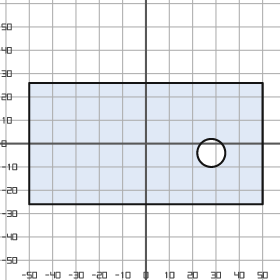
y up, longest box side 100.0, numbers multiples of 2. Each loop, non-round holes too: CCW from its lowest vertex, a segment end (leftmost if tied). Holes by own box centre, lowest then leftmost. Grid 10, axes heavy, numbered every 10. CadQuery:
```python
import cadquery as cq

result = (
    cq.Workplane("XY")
    .moveTo(-50.0, -26.0)
    .lineTo(50.0, -26.0)
    .lineTo(50.0, 26.0)
    .lineTo(-50.0, 26.0)
    .close()
    .moveTo(28.0, -4.0)
    .circle(6.0)
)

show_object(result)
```